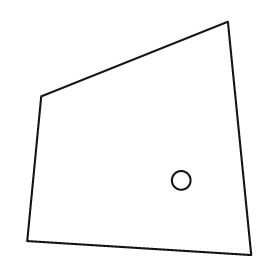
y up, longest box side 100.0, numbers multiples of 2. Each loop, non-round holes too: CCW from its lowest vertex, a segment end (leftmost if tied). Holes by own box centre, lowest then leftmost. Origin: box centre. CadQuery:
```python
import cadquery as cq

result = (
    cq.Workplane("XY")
    .moveTo(48.0, -50.0)
    .lineTo(38.0, 50.0)
    .lineTo(-42.0, 18.0)
    .lineTo(-48.0, -44.0)
    .close()
    .moveTo(18.0, -18.0)
    .circle(4.0)
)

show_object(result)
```